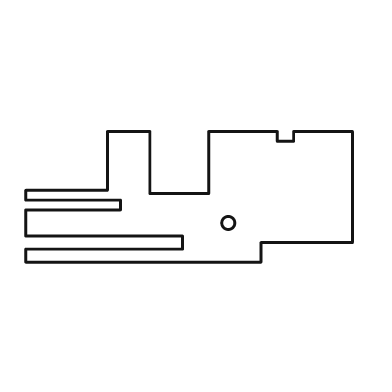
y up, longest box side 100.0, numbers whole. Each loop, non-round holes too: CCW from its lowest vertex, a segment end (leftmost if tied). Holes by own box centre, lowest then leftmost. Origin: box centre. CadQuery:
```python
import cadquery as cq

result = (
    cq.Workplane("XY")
    .moveTo(-50.0, -20.0)
    .lineTo(22.0, -20.0)
    .lineTo(22.0, -14.0)
    .lineTo(50.0, -14.0)
    .lineTo(50.0, 20.0)
    .lineTo(32.0, 20.0)
    .lineTo(32.0, 17.0)
    .lineTo(27.0, 17.0)
    .lineTo(27.0, 20.0)
    .lineTo(6.0, 20.0)
    .lineTo(6.0, 1.0)
    .lineTo(-12.0, 1.0)
    .lineTo(-12.0, 20.0)
    .lineTo(-25.0, 20.0)
    .lineTo(-25.0, 2.0)
    .lineTo(-50.0, 2.0)
    .lineTo(-50.0, -1.0)
    .lineTo(-21.0, -1.0)
    .lineTo(-21.0, -4.0)
    .lineTo(-50.0, -4.0)
    .lineTo(-50.0, -12.0)
    .lineTo(-2.0, -12.0)
    .lineTo(-2.0, -16.0)
    .lineTo(-50.0, -16.0)
    .close()
    .moveTo(12.0, -8.0)
    .circle(2.0)
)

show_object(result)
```